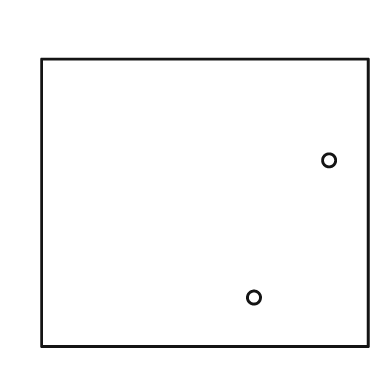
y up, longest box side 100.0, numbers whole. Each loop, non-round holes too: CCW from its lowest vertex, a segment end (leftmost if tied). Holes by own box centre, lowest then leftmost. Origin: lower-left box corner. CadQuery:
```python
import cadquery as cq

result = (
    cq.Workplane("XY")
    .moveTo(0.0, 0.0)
    .lineTo(100.0, 0.0)
    .lineTo(100.0, 88.0)
    .lineTo(0.0, 88.0)
    .close()
    .moveTo(65.0, 15.0)
    .circle(2.0)
    .moveTo(88.0, 57.0)
    .circle(2.0)
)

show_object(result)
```